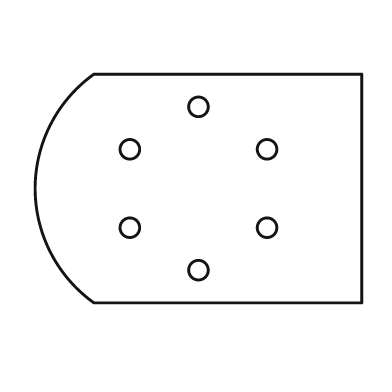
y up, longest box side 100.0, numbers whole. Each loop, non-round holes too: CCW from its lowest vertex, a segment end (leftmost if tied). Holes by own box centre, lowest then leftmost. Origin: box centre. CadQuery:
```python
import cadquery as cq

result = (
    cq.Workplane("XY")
    .moveTo(-32.0, -35.0)
    .lineTo(50.0, -35.0)
    .lineTo(50.0, 35.0)
    .lineTo(-32.0, 35.0)
    .threePointArc((-50.0, 0.0), (-32.0, -35.0))
    .close()
    .moveTo(0.0, -25.0)
    .circle(3.0)
    .moveTo(-21.0, -12.0)
    .circle(3.0)
    .moveTo(21.0, -12.0)
    .circle(3.0)
    .moveTo(-21.0, 12.0)
    .circle(3.0)
    .moveTo(21.0, 12.0)
    .circle(3.0)
    .moveTo(0.0, 25.0)
    .circle(3.0)
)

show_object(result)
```